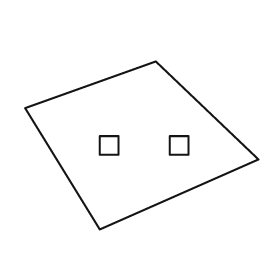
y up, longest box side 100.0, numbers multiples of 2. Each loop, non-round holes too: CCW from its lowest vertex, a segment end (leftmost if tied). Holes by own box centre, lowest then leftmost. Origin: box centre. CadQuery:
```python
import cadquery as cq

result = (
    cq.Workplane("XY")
    .moveTo(-18.0, -36.0)
    .lineTo(50.0, -6.0)
    .lineTo(6.0, 36.0)
    .lineTo(-50.0, 16.0)
    .close()
    .moveTo(-18.0, -4.0)
    .lineTo(-10.0, -4.0)
    .lineTo(-10.0, 4.0)
    .lineTo(-18.0, 4.0)
    .close()
    .moveTo(12.0, -4.0)
    .lineTo(20.0, -4.0)
    .lineTo(20.0, 4.0)
    .lineTo(12.0, 4.0)
    .close()
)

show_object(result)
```